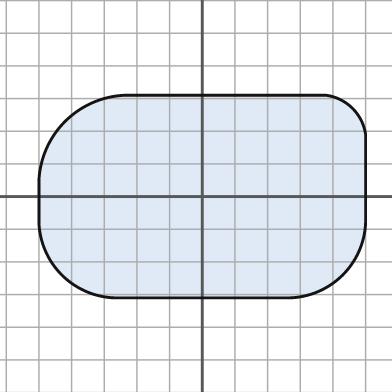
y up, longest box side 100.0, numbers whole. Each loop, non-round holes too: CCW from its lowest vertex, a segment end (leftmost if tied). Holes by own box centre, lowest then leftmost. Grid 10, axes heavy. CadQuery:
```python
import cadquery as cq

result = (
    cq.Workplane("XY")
    .moveTo(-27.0, -31.0)
    .lineTo(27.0, -31.0)
    .threePointArc((43.0, -24.0), (50.0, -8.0))
    .lineTo(50.0, 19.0)
    .threePointArc((46.0, 27.0), (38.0, 31.0))
    .lineTo(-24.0, 31.0)
    .threePointArc((-42.0, 23.0), (-50.0, 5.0))
    .lineTo(-50.0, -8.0)
    .threePointArc((-43.0, -24.0), (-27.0, -31.0))
    .close()
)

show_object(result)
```